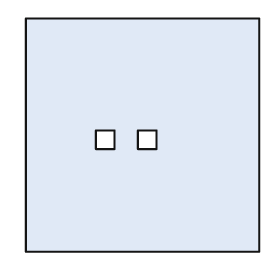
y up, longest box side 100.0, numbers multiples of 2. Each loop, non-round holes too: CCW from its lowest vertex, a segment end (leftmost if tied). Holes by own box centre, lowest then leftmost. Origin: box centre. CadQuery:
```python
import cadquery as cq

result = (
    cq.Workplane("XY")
    .moveTo(-50.0, -50.0)
    .lineTo(50.0, -50.0)
    .lineTo(50.0, 50.0)
    .lineTo(-50.0, 50.0)
    .close()
    .moveTo(-20.0, -6.0)
    .lineTo(-12.0, -6.0)
    .lineTo(-12.0, 2.0)
    .lineTo(-20.0, 2.0)
    .close()
    .moveTo(-2.0, -6.0)
    .lineTo(6.0, -6.0)
    .lineTo(6.0, 2.0)
    .lineTo(-2.0, 2.0)
    .close()
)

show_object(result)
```